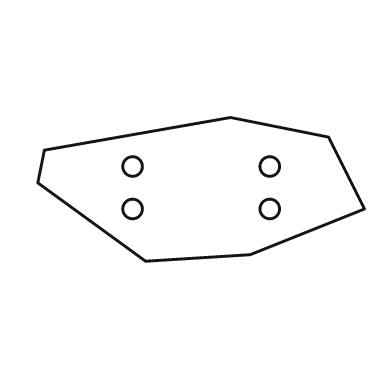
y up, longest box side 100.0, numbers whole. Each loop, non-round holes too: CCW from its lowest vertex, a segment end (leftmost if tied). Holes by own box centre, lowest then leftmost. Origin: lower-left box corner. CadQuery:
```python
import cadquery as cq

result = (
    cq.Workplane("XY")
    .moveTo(33.0, 0.0)
    .lineTo(65.0, 2.0)
    .lineTo(100.0, 16.0)
    .lineTo(89.0, 38.0)
    .lineTo(59.0, 44.0)
    .lineTo(2.0, 34.0)
    .lineTo(0.0, 24.0)
    .close()
    .moveTo(29.0, 16.0)
    .circle(3.0)
    .moveTo(71.0, 16.0)
    .circle(3.0)
    .moveTo(29.0, 29.0)
    .circle(3.0)
    .moveTo(71.0, 29.0)
    .circle(3.0)
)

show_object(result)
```